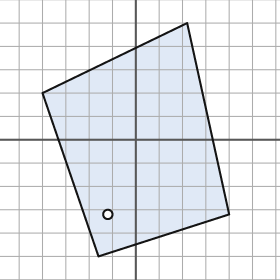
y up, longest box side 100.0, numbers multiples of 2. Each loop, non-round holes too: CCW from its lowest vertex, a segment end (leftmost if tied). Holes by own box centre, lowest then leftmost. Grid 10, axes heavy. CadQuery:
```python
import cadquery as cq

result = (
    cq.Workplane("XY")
    .moveTo(-16.0, -50.0)
    .lineTo(40.0, -32.0)
    .lineTo(22.0, 50.0)
    .lineTo(-40.0, 20.0)
    .close()
    .moveTo(-12.0, -32.0)
    .circle(2.0)
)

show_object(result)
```